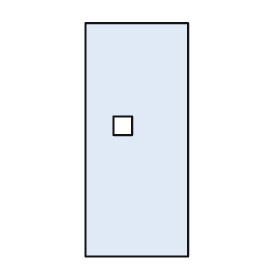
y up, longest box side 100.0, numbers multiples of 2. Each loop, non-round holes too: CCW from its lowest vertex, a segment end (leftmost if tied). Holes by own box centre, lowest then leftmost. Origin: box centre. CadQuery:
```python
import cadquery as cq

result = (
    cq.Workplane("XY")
    .moveTo(-22.0, -50.0)
    .lineTo(22.0, -50.0)
    .lineTo(22.0, 50.0)
    .lineTo(-22.0, 50.0)
    .close()
    .moveTo(-10.0, 2.0)
    .lineTo(-2.0, 2.0)
    .lineTo(-2.0, 10.0)
    .lineTo(-10.0, 10.0)
    .close()
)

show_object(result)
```